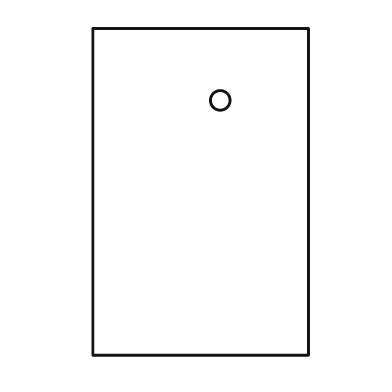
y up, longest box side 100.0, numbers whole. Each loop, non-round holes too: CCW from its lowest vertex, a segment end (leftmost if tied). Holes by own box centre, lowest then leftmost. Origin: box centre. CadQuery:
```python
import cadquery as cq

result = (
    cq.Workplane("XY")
    .moveTo(-33.0, -50.0)
    .lineTo(33.0, -50.0)
    .lineTo(33.0, 50.0)
    .lineTo(-33.0, 50.0)
    .close()
    .moveTo(6.0, 28.0)
    .circle(3.0)
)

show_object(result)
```